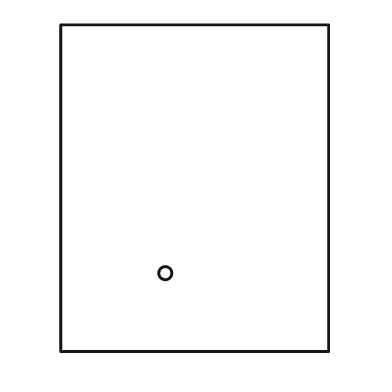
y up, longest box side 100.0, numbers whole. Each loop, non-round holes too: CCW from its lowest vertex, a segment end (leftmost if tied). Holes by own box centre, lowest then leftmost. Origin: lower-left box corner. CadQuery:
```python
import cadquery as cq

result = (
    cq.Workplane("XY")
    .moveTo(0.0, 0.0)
    .lineTo(82.0, 0.0)
    .lineTo(82.0, 100.0)
    .lineTo(0.0, 100.0)
    .close()
    .moveTo(32.0, 24.0)
    .circle(2.0)
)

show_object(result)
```